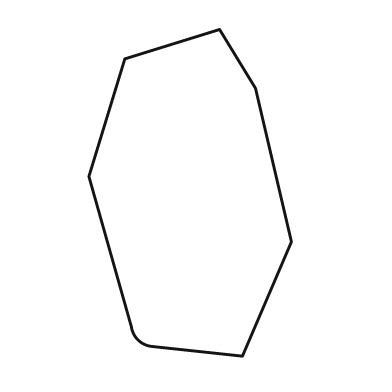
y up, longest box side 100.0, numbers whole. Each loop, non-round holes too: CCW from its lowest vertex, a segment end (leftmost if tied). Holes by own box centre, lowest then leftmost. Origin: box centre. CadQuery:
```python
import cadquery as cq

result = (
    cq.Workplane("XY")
    .moveTo(16.0, -50.0)
    .lineTo(31.0, -15.0)
    .lineTo(20.0, 32.0)
    .lineTo(9.0, 50.0)
    .lineTo(-20.0, 41.0)
    .lineTo(-31.0, 5.0)
    .lineTo(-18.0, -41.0)
    .threePointArc((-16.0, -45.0), (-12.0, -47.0))
    .close()
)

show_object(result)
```